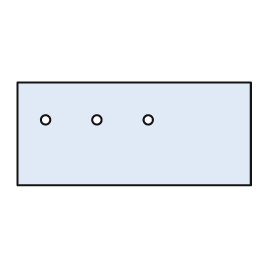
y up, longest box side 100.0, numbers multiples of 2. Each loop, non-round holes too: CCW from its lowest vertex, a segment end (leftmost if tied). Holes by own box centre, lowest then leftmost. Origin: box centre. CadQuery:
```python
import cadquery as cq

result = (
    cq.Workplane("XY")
    .moveTo(-50.0, -22.0)
    .lineTo(50.0, -22.0)
    .lineTo(50.0, 22.0)
    .lineTo(-50.0, 22.0)
    .close()
    .moveTo(-38.0, 6.0)
    .circle(2.0)
    .moveTo(-16.0, 6.0)
    .circle(2.0)
    .moveTo(6.0, 6.0)
    .circle(2.0)
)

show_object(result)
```